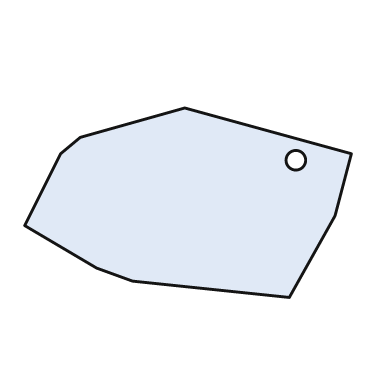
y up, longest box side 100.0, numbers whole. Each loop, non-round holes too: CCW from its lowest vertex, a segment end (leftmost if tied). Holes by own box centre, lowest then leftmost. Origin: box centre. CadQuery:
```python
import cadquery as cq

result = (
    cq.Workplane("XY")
    .moveTo(31.0, -29.0)
    .lineTo(45.0, -4.0)
    .lineTo(50.0, 15.0)
    .lineTo(-1.0, 29.0)
    .lineTo(-33.0, 20.0)
    .lineTo(-39.0, 15.0)
    .lineTo(-50.0, -7.0)
    .lineTo(-28.0, -20.0)
    .lineTo(-17.0, -24.0)
    .close()
    .moveTo(33.0, 13.0)
    .circle(3.0)
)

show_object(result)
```